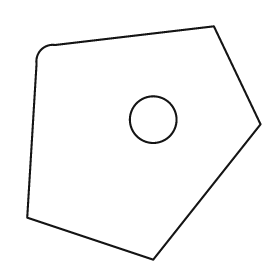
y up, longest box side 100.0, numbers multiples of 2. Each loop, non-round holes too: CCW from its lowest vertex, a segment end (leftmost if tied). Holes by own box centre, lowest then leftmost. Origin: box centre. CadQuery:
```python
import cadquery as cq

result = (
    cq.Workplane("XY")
    .moveTo(4.0, -50.0)
    .lineTo(50.0, 8.0)
    .lineTo(30.0, 50.0)
    .lineTo(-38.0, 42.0)
    .threePointArc((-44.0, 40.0), (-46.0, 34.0))
    .lineTo(-50.0, -32.0)
    .close()
    .moveTo(4.0, 10.0)
    .circle(10.0)
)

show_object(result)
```